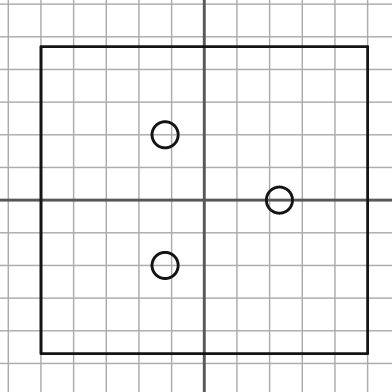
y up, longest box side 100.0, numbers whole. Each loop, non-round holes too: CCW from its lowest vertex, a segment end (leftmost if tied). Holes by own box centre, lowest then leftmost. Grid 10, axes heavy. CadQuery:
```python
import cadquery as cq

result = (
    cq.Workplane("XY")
    .moveTo(-50.0, -47.0)
    .lineTo(50.0, -47.0)
    .lineTo(50.0, 47.0)
    .lineTo(-50.0, 47.0)
    .close()
    .moveTo(-12.0, -20.0)
    .circle(4.0)
    .moveTo(23.0, 0.0)
    .circle(4.0)
    .moveTo(-12.0, 20.0)
    .circle(4.0)
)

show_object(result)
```